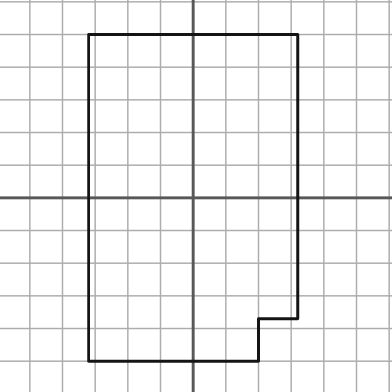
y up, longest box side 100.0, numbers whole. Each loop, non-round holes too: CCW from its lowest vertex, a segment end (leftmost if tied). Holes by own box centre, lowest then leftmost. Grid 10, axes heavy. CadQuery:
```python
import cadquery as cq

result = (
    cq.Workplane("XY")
    .moveTo(-32.0, -50.0)
    .lineTo(20.0, -50.0)
    .lineTo(20.0, -37.0)
    .lineTo(32.0, -37.0)
    .lineTo(32.0, 50.0)
    .lineTo(-32.0, 50.0)
    .close()
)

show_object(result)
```